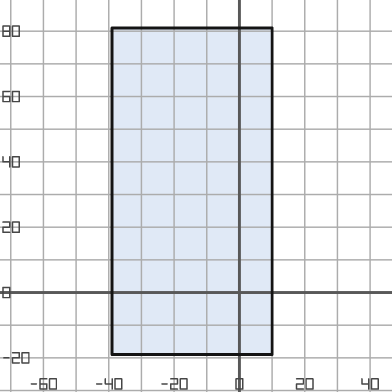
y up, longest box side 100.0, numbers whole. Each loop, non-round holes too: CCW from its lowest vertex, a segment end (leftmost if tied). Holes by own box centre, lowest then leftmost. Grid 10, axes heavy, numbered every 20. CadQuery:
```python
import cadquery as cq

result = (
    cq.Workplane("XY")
    .moveTo(-39.0, -19.0)
    .lineTo(10.0, -19.0)
    .lineTo(10.0, 81.0)
    .lineTo(-39.0, 81.0)
    .close()
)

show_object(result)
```